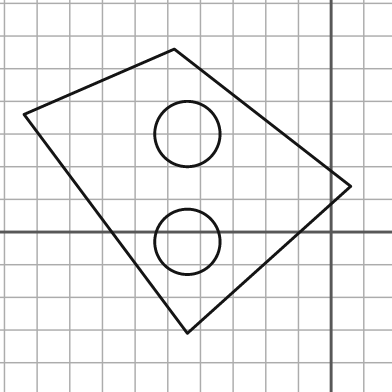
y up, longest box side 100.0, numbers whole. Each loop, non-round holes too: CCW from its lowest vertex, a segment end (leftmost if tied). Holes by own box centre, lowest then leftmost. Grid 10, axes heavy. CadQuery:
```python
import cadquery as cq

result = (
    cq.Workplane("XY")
    .moveTo(-44.0, -31.0)
    .lineTo(6.0, 14.0)
    .lineTo(-48.0, 56.0)
    .lineTo(-94.0, 36.0)
    .close()
    .moveTo(-44.0, -3.0)
    .circle(10.0)
    .moveTo(-44.0, 30.0)
    .circle(10.0)
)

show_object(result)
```